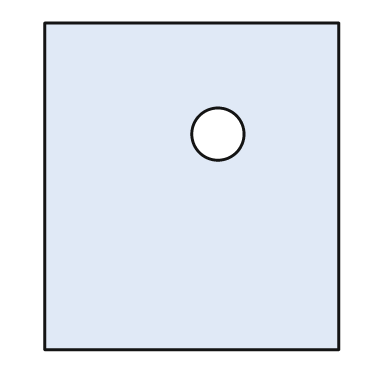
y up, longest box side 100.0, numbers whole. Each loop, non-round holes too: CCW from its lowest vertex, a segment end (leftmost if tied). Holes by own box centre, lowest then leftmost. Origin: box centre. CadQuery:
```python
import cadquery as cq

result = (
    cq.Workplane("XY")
    .moveTo(-45.0, -50.0)
    .lineTo(45.0, -50.0)
    .lineTo(45.0, 50.0)
    .lineTo(-45.0, 50.0)
    .close()
    .moveTo(8.0, 16.0)
    .circle(8.0)
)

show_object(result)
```